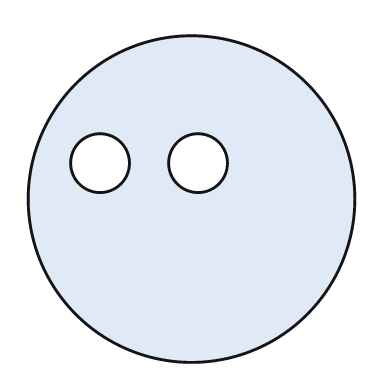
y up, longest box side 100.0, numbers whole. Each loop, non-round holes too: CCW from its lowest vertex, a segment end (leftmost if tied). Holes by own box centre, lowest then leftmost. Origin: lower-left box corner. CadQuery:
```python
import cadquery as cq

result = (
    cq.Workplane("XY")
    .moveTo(50.0, 50.0)
    .circle(50.0)
    .moveTo(22.0, 61.0)
    .circle(9.0)
    .moveTo(52.0, 61.0)
    .circle(9.0)
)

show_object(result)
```